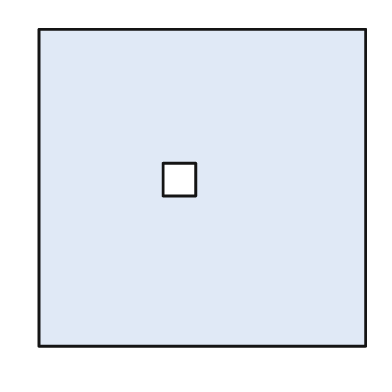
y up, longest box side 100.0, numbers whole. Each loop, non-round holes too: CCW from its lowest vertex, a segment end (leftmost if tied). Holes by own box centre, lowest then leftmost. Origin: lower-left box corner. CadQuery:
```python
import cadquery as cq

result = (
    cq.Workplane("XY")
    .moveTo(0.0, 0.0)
    .lineTo(100.0, 0.0)
    .lineTo(100.0, 97.0)
    .lineTo(0.0, 97.0)
    .close()
    .moveTo(38.0, 46.0)
    .lineTo(48.0, 46.0)
    .lineTo(48.0, 56.0)
    .lineTo(38.0, 56.0)
    .close()
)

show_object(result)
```